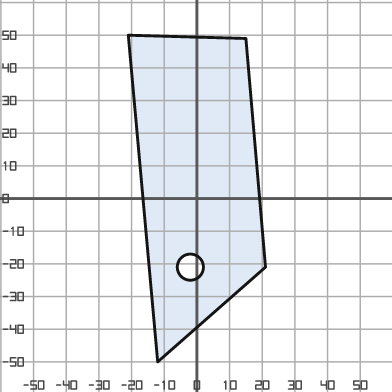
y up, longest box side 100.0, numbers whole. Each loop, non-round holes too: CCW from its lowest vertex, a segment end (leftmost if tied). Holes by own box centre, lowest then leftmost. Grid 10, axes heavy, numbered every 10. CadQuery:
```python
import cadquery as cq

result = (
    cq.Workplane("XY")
    .moveTo(-12.0, -50.0)
    .lineTo(21.0, -21.0)
    .lineTo(15.0, 49.0)
    .lineTo(-21.0, 50.0)
    .close()
    .moveTo(-2.0, -21.0)
    .circle(4.0)
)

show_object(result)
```